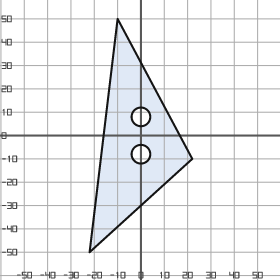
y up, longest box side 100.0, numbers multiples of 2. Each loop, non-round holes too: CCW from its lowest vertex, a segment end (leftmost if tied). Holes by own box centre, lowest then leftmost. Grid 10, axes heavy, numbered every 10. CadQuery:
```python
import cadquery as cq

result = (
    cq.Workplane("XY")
    .moveTo(-22.0, -50.0)
    .lineTo(22.0, -10.0)
    .lineTo(-10.0, 50.0)
    .close()
    .moveTo(0.0, -8.0)
    .circle(4.0)
    .moveTo(0.0, 8.0)
    .circle(4.0)
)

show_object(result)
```